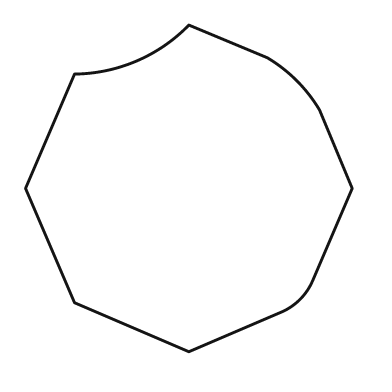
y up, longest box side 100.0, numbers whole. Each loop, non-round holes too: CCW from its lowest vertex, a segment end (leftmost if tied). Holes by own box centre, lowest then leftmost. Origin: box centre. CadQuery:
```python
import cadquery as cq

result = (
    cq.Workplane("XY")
    .moveTo(0.0, -50.0)
    .lineTo(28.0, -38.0)
    .threePointArc((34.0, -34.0), (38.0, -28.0))
    .lineTo(50.0, 0.0)
    .lineTo(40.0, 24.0)
    .threePointArc((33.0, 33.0), (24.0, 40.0))
    .lineTo(0.0, 50.0)
    .threePointArc((-16.0, 39.0), (-35.0, 35.0))
    .lineTo(-50.0, 0.0)
    .lineTo(-35.0, -35.0)
    .close()
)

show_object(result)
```